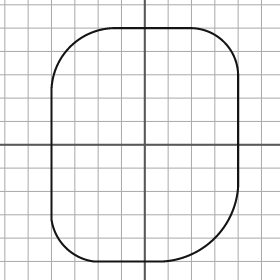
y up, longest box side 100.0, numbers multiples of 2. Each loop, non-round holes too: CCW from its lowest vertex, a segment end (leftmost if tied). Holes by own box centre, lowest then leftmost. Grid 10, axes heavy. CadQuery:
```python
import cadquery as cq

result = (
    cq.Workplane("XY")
    .moveTo(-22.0, -50.0)
    .lineTo(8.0, -50.0)
    .threePointArc((30.0, -40.0), (40.0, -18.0))
    .lineTo(40.0, 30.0)
    .threePointArc((34.0, 44.0), (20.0, 50.0))
    .lineTo(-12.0, 50.0)
    .threePointArc((-32.0, 42.0), (-40.0, 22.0))
    .lineTo(-40.0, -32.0)
    .threePointArc((-34.0, -44.0), (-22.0, -50.0))
    .close()
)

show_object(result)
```